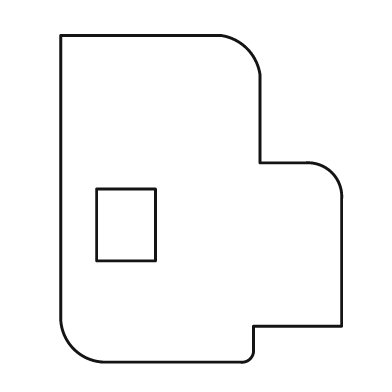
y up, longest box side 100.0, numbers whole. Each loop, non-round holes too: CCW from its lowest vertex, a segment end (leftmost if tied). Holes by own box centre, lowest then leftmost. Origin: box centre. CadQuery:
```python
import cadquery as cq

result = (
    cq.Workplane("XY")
    .moveTo(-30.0, -50.0)
    .lineTo(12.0, -50.0)
    .threePointArc((15.0, -49.0), (16.0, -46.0))
    .lineTo(16.0, -39.0)
    .lineTo(43.0, -39.0)
    .lineTo(43.0, 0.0)
    .threePointArc((40.0, 8.0), (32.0, 11.0))
    .lineTo(18.0, 11.0)
    .lineTo(18.0, 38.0)
    .threePointArc((14.0, 46.0), (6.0, 50.0))
    .lineTo(-43.0, 50.0)
    .lineTo(-43.0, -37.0)
    .threePointArc((-39.0, -46.0), (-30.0, -50.0))
    .close()
    .moveTo(-32.0, -19.0)
    .lineTo(-14.0, -19.0)
    .lineTo(-14.0, 3.0)
    .lineTo(-32.0, 3.0)
    .close()
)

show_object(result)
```